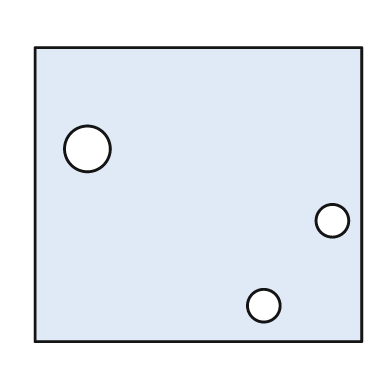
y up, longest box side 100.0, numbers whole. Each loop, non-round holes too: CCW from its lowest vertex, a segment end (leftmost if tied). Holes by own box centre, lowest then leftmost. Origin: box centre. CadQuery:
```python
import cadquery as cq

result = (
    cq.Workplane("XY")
    .moveTo(-50.0, -45.0)
    .lineTo(50.0, -45.0)
    .lineTo(50.0, 45.0)
    .lineTo(-50.0, 45.0)
    .close()
    .moveTo(20.0, -34.0)
    .circle(5.0)
    .moveTo(41.0, -8.0)
    .circle(5.0)
    .moveTo(-34.0, 14.0)
    .circle(7.0)
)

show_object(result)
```